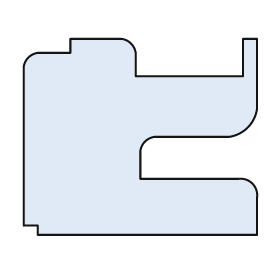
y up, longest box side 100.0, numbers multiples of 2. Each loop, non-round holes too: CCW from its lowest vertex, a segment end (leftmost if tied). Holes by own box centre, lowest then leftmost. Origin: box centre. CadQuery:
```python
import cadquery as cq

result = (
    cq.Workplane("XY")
    .moveTo(-44.0, -42.0)
    .lineTo(50.0, -42.0)
    .lineTo(50.0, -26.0)
    .threePointArc((48.0, -20.0), (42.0, -18.0))
    .lineTo(0.0, -18.0)
    .lineTo(0.0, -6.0)
    .threePointArc((2.0, -2.0), (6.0, 0.0))
    .lineTo(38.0, 0.0)
    .threePointArc((46.0, 4.0), (50.0, 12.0))
    .lineTo(50.0, 42.0)
    .lineTo(44.0, 42.0)
    .lineTo(44.0, 26.0)
    .lineTo(-2.0, 26.0)
    .lineTo(-2.0, 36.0)
    .threePointArc((-4.0, 40.0), (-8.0, 42.0))
    .lineTo(-30.0, 42.0)
    .lineTo(-30.0, 36.0)
    .lineTo(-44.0, 36.0)
    .threePointArc((-48.0, 34.0), (-50.0, 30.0))
    .lineTo(-50.0, -38.0)
    .lineTo(-44.0, -38.0)
    .close()
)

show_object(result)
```